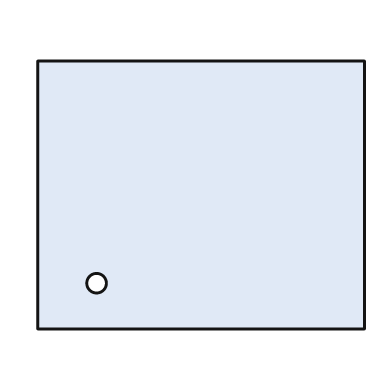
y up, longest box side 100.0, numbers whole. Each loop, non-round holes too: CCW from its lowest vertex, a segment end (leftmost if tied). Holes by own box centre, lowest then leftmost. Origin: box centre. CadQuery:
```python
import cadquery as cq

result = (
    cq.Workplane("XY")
    .moveTo(-50.0, -41.0)
    .lineTo(50.0, -41.0)
    .lineTo(50.0, 41.0)
    .lineTo(-50.0, 41.0)
    .close()
    .moveTo(-32.0, -27.0)
    .circle(3.0)
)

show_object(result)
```